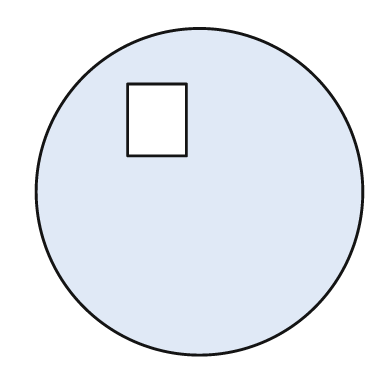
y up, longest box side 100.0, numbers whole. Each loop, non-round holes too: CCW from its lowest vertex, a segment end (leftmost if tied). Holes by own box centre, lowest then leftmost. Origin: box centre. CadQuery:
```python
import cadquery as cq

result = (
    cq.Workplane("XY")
    .moveTo(0.0, 0.0)
    .circle(50.0)
    .moveTo(-22.0, 11.0)
    .lineTo(-4.0, 11.0)
    .lineTo(-4.0, 33.0)
    .lineTo(-22.0, 33.0)
    .close()
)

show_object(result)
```